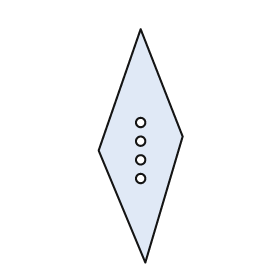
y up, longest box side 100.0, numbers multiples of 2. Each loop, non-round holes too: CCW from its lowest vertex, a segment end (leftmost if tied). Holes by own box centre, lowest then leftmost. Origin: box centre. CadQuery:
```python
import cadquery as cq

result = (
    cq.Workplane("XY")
    .moveTo(2.0, -50.0)
    .lineTo(18.0, 4.0)
    .lineTo(0.0, 50.0)
    .lineTo(-18.0, -2.0)
    .close()
    .moveTo(0.0, -14.0)
    .circle(2.0)
    .moveTo(0.0, -6.0)
    .circle(2.0)
    .moveTo(0.0, 2.0)
    .circle(2.0)
    .moveTo(0.0, 10.0)
    .circle(2.0)
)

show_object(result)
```